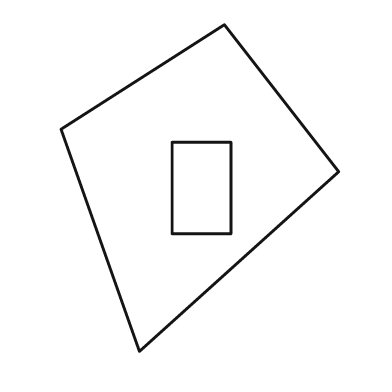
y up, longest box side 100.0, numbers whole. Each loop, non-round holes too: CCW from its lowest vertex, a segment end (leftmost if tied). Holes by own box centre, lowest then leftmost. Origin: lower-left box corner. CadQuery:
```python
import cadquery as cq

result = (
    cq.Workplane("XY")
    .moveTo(24.0, 0.0)
    .lineTo(85.0, 55.0)
    .lineTo(50.0, 100.0)
    .lineTo(0.0, 68.0)
    .close()
    .moveTo(34.0, 36.0)
    .lineTo(52.0, 36.0)
    .lineTo(52.0, 64.0)
    .lineTo(34.0, 64.0)
    .close()
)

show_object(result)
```